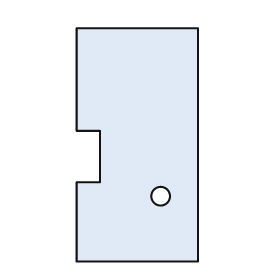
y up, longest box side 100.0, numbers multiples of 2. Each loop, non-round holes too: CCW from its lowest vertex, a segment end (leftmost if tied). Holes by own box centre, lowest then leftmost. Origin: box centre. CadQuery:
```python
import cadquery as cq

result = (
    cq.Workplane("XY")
    .moveTo(-26.0, -50.0)
    .lineTo(26.0, -50.0)
    .lineTo(26.0, 50.0)
    .lineTo(-26.0, 50.0)
    .lineTo(-26.0, 6.0)
    .lineTo(-16.0, 6.0)
    .lineTo(-16.0, -16.0)
    .lineTo(-26.0, -16.0)
    .close()
    .moveTo(10.0, -22.0)
    .circle(4.0)
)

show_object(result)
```